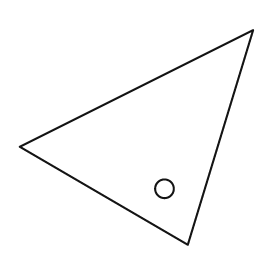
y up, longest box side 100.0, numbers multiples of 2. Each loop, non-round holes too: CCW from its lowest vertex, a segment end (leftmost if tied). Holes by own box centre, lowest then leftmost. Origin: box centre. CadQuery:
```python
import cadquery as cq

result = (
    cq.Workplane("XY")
    .moveTo(22.0, -46.0)
    .lineTo(50.0, 46.0)
    .lineTo(-50.0, -4.0)
    .close()
    .moveTo(12.0, -22.0)
    .circle(4.0)
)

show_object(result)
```